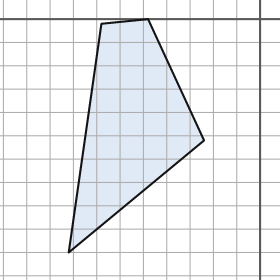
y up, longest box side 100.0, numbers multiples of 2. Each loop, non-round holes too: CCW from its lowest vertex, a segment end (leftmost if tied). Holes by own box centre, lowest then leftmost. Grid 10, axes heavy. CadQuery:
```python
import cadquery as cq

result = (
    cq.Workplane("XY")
    .moveTo(-82.0, -100.0)
    .lineTo(-24.0, -52.0)
    .lineTo(-48.0, 0.0)
    .lineTo(-68.0, -2.0)
    .close()
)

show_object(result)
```